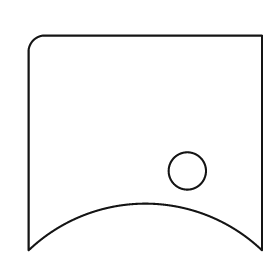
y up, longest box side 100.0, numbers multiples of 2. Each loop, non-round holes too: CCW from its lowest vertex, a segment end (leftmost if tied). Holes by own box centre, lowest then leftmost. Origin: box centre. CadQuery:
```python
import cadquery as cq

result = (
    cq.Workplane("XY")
    .moveTo(-50.0, -46.0)
    .threePointArc((0.0, -26.0), (50.0, -46.0))
    .lineTo(50.0, 46.0)
    .lineTo(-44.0, 46.0)
    .threePointArc((-48.0, 44.0), (-50.0, 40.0))
    .close()
    .moveTo(18.0, -12.0)
    .circle(8.0)
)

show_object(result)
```